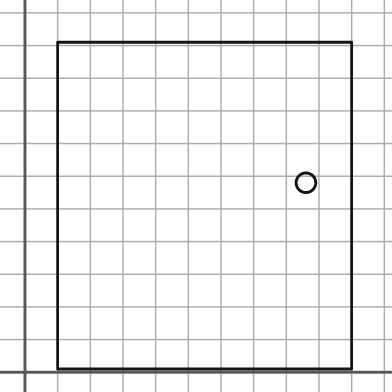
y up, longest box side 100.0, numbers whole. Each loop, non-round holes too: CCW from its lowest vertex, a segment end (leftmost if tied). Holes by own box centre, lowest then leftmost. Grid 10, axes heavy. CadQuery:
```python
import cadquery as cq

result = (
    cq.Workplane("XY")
    .moveTo(10.0, 1.0)
    .lineTo(100.0, 1.0)
    .lineTo(100.0, 101.0)
    .lineTo(10.0, 101.0)
    .close()
    .moveTo(86.0, 58.0)
    .circle(3.0)
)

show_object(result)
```